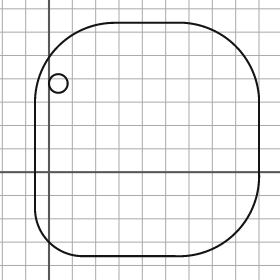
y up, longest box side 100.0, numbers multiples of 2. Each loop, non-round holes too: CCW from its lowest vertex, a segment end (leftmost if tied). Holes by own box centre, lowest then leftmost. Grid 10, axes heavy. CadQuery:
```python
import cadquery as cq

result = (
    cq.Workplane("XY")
    .moveTo(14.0, -36.0)
    .lineTo(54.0, -36.0)
    .threePointArc((80.0, -26.0), (90.0, 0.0))
    .lineTo(90.0, 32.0)
    .threePointArc((80.0, 54.0), (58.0, 64.0))
    .lineTo(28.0, 64.0)
    .threePointArc((4.0, 54.0), (-6.0, 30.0))
    .lineTo(-6.0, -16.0)
    .threePointArc((0.0, -30.0), (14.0, -36.0))
    .close()
    .moveTo(4.0, 38.0)
    .circle(4.0)
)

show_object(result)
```